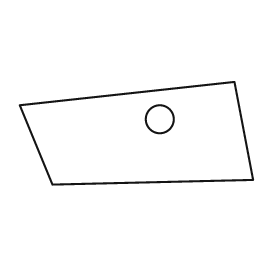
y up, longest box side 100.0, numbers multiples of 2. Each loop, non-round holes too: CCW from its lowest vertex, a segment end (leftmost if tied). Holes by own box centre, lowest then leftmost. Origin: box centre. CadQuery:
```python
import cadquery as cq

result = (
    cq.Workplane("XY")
    .moveTo(-36.0, -22.0)
    .lineTo(50.0, -20.0)
    .lineTo(42.0, 22.0)
    .lineTo(-50.0, 12.0)
    .close()
    .moveTo(10.0, 6.0)
    .circle(6.0)
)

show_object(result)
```